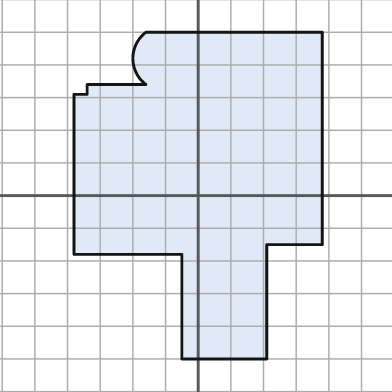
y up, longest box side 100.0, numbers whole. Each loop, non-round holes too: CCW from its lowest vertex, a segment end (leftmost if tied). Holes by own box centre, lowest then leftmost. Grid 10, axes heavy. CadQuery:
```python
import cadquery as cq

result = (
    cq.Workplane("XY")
    .moveTo(-5.0, -50.0)
    .lineTo(21.0, -50.0)
    .lineTo(21.0, -15.0)
    .lineTo(38.0, -15.0)
    .lineTo(38.0, 50.0)
    .lineTo(-16.0, 50.0)
    .threePointArc((-20.0, 42.0), (-16.0, 34.0))
    .lineTo(-34.0, 34.0)
    .lineTo(-34.0, 31.0)
    .lineTo(-38.0, 31.0)
    .lineTo(-38.0, -18.0)
    .lineTo(-5.0, -18.0)
    .close()
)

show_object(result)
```